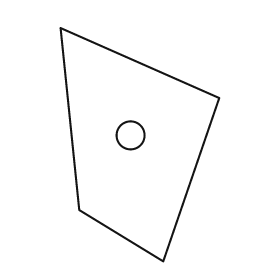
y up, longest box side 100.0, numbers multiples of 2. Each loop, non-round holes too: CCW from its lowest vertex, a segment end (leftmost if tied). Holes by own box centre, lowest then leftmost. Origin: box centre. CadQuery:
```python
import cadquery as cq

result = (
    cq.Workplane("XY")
    .moveTo(10.0, -50.0)
    .lineTo(34.0, 20.0)
    .lineTo(-34.0, 50.0)
    .lineTo(-26.0, -28.0)
    .close()
    .moveTo(-4.0, 4.0)
    .circle(6.0)
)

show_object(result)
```